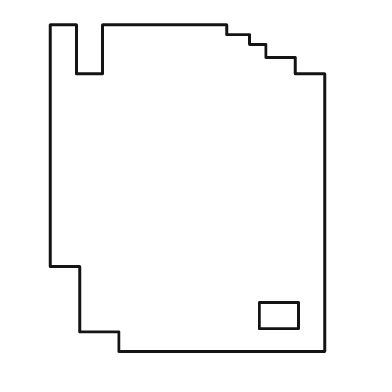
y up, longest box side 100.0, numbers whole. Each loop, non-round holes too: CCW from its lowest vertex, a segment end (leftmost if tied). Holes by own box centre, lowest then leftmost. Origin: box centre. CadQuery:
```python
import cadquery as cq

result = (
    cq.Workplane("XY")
    .moveTo(-21.0, -50.0)
    .lineTo(42.0, -50.0)
    .lineTo(42.0, 35.0)
    .lineTo(33.0, 35.0)
    .lineTo(33.0, 40.0)
    .lineTo(24.0, 40.0)
    .lineTo(24.0, 44.0)
    .lineTo(19.0, 44.0)
    .lineTo(19.0, 47.0)
    .lineTo(12.0, 47.0)
    .lineTo(12.0, 50.0)
    .lineTo(-26.0, 50.0)
    .lineTo(-26.0, 35.0)
    .lineTo(-34.0, 35.0)
    .lineTo(-34.0, 50.0)
    .lineTo(-42.0, 50.0)
    .lineTo(-42.0, -24.0)
    .lineTo(-33.0, -24.0)
    .lineTo(-33.0, -44.0)
    .lineTo(-21.0, -44.0)
    .close()
    .moveTo(22.0, -43.0)
    .lineTo(34.0, -43.0)
    .lineTo(34.0, -35.0)
    .lineTo(22.0, -35.0)
    .close()
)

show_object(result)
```